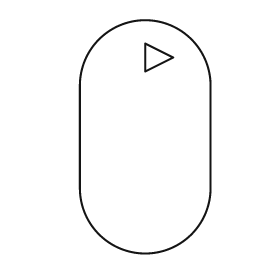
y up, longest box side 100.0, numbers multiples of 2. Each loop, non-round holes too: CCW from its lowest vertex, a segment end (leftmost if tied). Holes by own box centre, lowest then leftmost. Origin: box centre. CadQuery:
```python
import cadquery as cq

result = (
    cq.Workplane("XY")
    .moveTo(-28.0, -22.0)
    .threePointArc((0.0, -50.0), (28.0, -22.0))
    .lineTo(28.0, 22.0)
    .threePointArc((0.0, 50.0), (-28.0, 22.0))
    .close()
    .moveTo(0.0, 28.0)
    .lineTo(12.0, 34.0)
    .lineTo(0.0, 40.0)
    .close()
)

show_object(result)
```